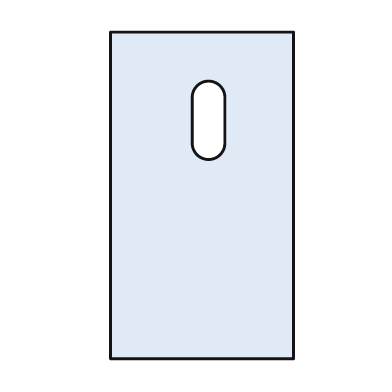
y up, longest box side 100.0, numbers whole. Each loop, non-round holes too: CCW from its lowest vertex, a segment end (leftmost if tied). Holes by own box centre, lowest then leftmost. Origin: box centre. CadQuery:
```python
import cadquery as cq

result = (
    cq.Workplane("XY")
    .moveTo(-28.0, -50.0)
    .lineTo(28.0, -50.0)
    .lineTo(28.0, 50.0)
    .lineTo(-28.0, 50.0)
    .close()
    .moveTo(-3.0, 16.0)
    .threePointArc((2.0, 11.0), (7.0, 16.0))
    .lineTo(7.0, 30.0)
    .threePointArc((2.0, 35.0), (-3.0, 30.0))
    .close()
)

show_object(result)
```